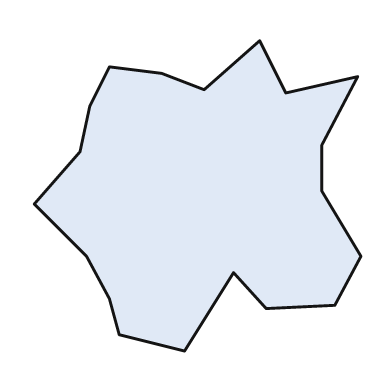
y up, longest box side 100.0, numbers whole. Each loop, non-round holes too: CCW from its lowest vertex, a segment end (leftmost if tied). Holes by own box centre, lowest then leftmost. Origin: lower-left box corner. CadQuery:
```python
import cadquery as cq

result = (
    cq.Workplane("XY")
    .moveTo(46.0, 0.0)
    .lineTo(61.0, 24.0)
    .lineTo(71.0, 13.0)
    .lineTo(92.0, 14.0)
    .lineTo(100.0, 29.0)
    .lineTo(88.0, 49.0)
    .lineTo(88.0, 63.0)
    .lineTo(99.0, 84.0)
    .lineTo(77.0, 79.0)
    .lineTo(69.0, 95.0)
    .lineTo(52.0, 80.0)
    .lineTo(39.0, 85.0)
    .lineTo(23.0, 87.0)
    .lineTo(17.0, 75.0)
    .lineTo(14.0, 61.0)
    .lineTo(0.0, 45.0)
    .lineTo(16.0, 29.0)
    .lineTo(23.0, 16.0)
    .lineTo(26.0, 5.0)
    .close()
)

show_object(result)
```